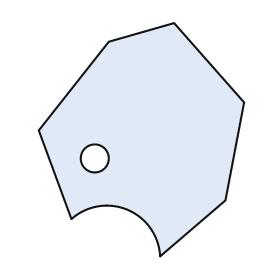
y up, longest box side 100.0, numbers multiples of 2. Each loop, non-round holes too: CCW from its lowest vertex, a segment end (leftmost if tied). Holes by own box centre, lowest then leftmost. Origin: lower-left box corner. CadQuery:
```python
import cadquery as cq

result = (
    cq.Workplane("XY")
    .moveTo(52.0, 0.0)
    .lineTo(80.0, 24.0)
    .lineTo(88.0, 66.0)
    .lineTo(58.0, 100.0)
    .lineTo(30.0, 92.0)
    .lineTo(0.0, 54.0)
    .lineTo(14.0, 16.0)
    .threePointArc((38.0, 20.0), (52.0, 0.0))
    .close()
    .moveTo(24.0, 42.0)
    .circle(6.0)
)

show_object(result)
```